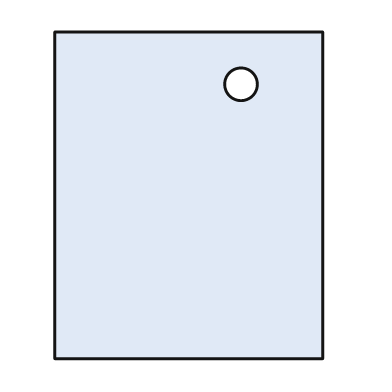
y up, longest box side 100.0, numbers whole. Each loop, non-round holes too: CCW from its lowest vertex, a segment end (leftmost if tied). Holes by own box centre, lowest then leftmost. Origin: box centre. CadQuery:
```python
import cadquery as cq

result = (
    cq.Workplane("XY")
    .moveTo(-41.0, -50.0)
    .lineTo(41.0, -50.0)
    .lineTo(41.0, 50.0)
    .lineTo(-41.0, 50.0)
    .close()
    .moveTo(16.0, 34.0)
    .circle(5.0)
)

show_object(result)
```